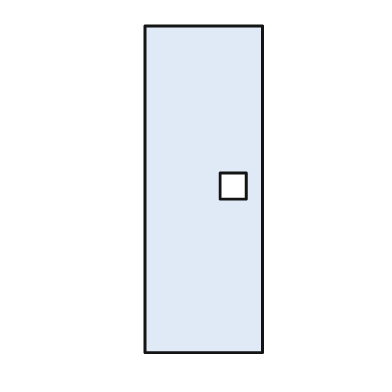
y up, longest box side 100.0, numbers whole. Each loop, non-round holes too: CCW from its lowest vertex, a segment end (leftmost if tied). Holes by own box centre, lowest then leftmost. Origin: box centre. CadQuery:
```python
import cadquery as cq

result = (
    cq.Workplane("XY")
    .moveTo(-18.0, -50.0)
    .lineTo(18.0, -50.0)
    .lineTo(18.0, 50.0)
    .lineTo(-18.0, 50.0)
    .close()
    .moveTo(5.0, -3.0)
    .lineTo(13.0, -3.0)
    .lineTo(13.0, 5.0)
    .lineTo(5.0, 5.0)
    .close()
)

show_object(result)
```